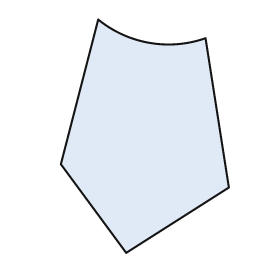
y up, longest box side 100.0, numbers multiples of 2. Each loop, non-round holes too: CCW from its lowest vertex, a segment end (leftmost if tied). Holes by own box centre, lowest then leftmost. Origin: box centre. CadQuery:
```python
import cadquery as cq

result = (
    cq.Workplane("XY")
    .moveTo(-8.0, -50.0)
    .lineTo(36.0, -22.0)
    .lineTo(26.0, 42.0)
    .threePointArc((2.0, 40.0), (-20.0, 50.0))
    .lineTo(-36.0, -12.0)
    .close()
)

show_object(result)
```